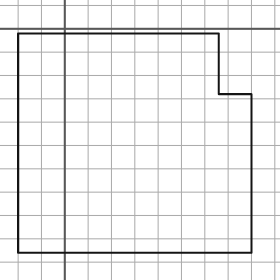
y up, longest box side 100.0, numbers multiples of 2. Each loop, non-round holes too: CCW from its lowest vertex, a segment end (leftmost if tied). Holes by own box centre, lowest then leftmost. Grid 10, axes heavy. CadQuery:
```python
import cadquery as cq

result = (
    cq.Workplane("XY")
    .moveTo(-20.0, -96.0)
    .lineTo(80.0, -96.0)
    .lineTo(80.0, -28.0)
    .lineTo(66.0, -28.0)
    .lineTo(66.0, -2.0)
    .lineTo(-20.0, -2.0)
    .close()
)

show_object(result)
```